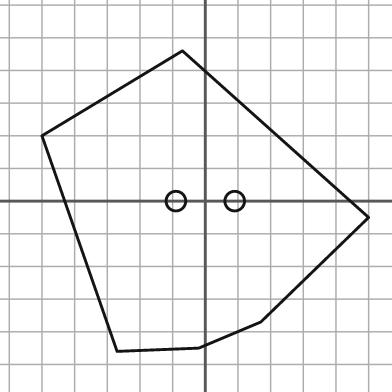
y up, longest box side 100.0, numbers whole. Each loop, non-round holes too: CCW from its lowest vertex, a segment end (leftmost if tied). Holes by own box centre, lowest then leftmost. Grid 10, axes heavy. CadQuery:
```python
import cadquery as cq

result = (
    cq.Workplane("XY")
    .moveTo(-27.0, -46.0)
    .lineTo(-2.0, -45.0)
    .lineTo(17.0, -37.0)
    .lineTo(50.0, -5.0)
    .lineTo(-7.0, 46.0)
    .lineTo(-50.0, 20.0)
    .close()
    .moveTo(-9.0, 0.0)
    .circle(3.0)
    .moveTo(9.0, 0.0)
    .circle(3.0)
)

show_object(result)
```